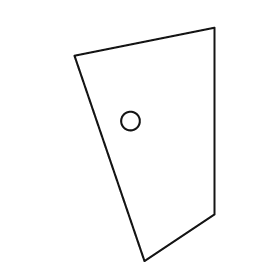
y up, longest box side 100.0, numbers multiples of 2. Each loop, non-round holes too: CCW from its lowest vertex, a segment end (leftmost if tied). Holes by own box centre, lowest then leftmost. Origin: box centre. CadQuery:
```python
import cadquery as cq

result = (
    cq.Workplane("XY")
    .moveTo(0.0, -50.0)
    .lineTo(30.0, -30.0)
    .lineTo(30.0, 50.0)
    .lineTo(-30.0, 38.0)
    .close()
    .moveTo(-6.0, 10.0)
    .circle(4.0)
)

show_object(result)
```